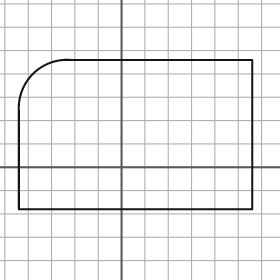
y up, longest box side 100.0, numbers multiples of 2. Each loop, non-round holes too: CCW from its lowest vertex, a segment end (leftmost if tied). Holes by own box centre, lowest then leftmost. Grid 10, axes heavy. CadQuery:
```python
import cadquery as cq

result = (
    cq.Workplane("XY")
    .moveTo(-44.0, -18.0)
    .lineTo(56.0, -18.0)
    .lineTo(56.0, 46.0)
    .lineTo(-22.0, 46.0)
    .threePointArc((-38.0, 40.0), (-44.0, 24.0))
    .close()
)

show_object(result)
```